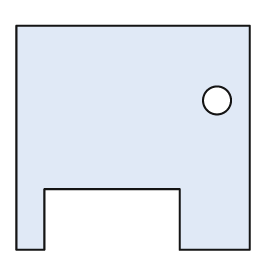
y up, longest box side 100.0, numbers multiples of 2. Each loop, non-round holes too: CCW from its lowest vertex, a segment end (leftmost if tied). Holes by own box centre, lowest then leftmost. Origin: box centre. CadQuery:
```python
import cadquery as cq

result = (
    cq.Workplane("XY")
    .moveTo(-50.0, -48.0)
    .lineTo(-38.0, -48.0)
    .lineTo(-38.0, -22.0)
    .lineTo(20.0, -22.0)
    .lineTo(20.0, -48.0)
    .lineTo(50.0, -48.0)
    .lineTo(50.0, 48.0)
    .lineTo(-50.0, 48.0)
    .close()
    .moveTo(36.0, 16.0)
    .circle(6.0)
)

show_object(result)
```